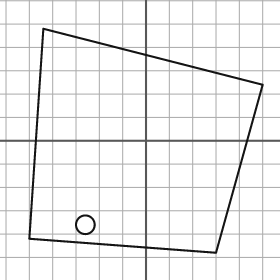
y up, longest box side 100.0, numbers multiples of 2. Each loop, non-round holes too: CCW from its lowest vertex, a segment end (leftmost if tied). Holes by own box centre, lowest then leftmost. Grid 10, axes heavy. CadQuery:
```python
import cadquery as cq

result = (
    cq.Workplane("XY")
    .moveTo(30.0, -48.0)
    .lineTo(50.0, 24.0)
    .lineTo(-44.0, 48.0)
    .lineTo(-50.0, -42.0)
    .close()
    .moveTo(-26.0, -36.0)
    .circle(4.0)
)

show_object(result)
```